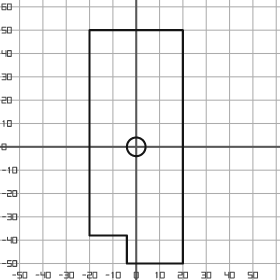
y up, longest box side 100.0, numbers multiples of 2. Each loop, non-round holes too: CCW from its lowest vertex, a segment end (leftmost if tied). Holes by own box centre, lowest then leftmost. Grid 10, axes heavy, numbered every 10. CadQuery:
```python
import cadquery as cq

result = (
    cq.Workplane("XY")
    .moveTo(-4.0, -50.0)
    .lineTo(20.0, -50.0)
    .lineTo(20.0, 50.0)
    .lineTo(-20.0, 50.0)
    .lineTo(-20.0, -38.0)
    .lineTo(-4.0, -38.0)
    .close()
    .moveTo(0.0, 0.0)
    .circle(4.0)
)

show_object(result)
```